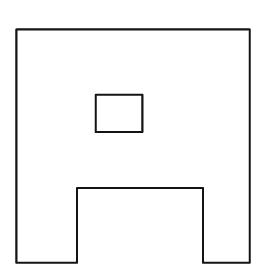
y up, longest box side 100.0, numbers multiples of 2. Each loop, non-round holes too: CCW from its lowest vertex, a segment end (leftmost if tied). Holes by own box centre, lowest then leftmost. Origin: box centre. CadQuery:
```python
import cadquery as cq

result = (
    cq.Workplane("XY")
    .moveTo(-50.0, -50.0)
    .lineTo(-24.0, -50.0)
    .lineTo(-24.0, -18.0)
    .lineTo(30.0, -18.0)
    .lineTo(30.0, -50.0)
    .lineTo(50.0, -50.0)
    .lineTo(50.0, 50.0)
    .lineTo(-50.0, 50.0)
    .close()
    .moveTo(-16.0, 6.0)
    .lineTo(4.0, 6.0)
    .lineTo(4.0, 22.0)
    .lineTo(-16.0, 22.0)
    .close()
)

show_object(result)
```